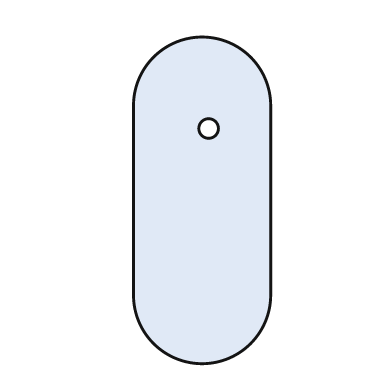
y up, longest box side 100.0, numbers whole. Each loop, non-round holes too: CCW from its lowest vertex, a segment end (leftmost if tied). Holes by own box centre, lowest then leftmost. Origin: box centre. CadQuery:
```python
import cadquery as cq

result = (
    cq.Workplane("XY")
    .moveTo(-21.0, -29.0)
    .threePointArc((0.0, -50.0), (21.0, -29.0))
    .lineTo(21.0, 29.0)
    .threePointArc((0.0, 50.0), (-21.0, 29.0))
    .close()
    .moveTo(2.0, 22.0)
    .circle(3.0)
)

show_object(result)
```